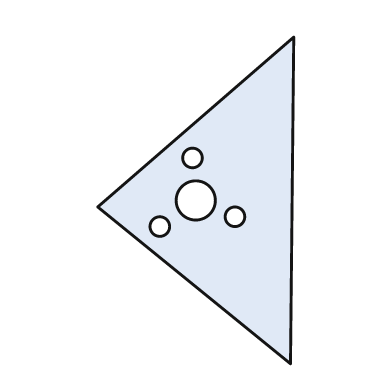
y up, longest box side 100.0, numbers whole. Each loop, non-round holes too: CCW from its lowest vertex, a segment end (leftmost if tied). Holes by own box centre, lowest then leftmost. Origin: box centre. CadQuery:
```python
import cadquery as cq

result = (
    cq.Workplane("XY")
    .moveTo(29.0, -50.0)
    .lineTo(30.0, 50.0)
    .lineTo(-30.0, -2.0)
    .close()
    .moveTo(-11.0, -8.0)
    .circle(3.0)
    .moveTo(12.0, -5.0)
    .circle(3.0)
    .moveTo(0.0, 0.0)
    .circle(6.0)
    .moveTo(-1.0, 13.0)
    .circle(3.0)
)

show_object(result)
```